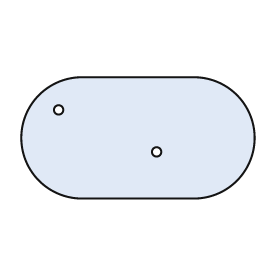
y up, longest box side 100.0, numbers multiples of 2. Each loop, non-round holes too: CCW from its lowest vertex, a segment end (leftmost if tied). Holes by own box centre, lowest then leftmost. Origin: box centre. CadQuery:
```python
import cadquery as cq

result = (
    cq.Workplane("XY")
    .moveTo(-24.0, -26.0)
    .lineTo(24.0, -26.0)
    .threePointArc((50.0, 0.0), (24.0, 26.0))
    .lineTo(-24.0, 26.0)
    .threePointArc((-50.0, 0.0), (-24.0, -26.0))
    .close()
    .moveTo(8.0, -6.0)
    .circle(2.0)
    .moveTo(-34.0, 12.0)
    .circle(2.0)
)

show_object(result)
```